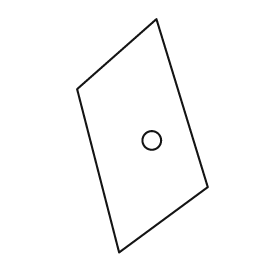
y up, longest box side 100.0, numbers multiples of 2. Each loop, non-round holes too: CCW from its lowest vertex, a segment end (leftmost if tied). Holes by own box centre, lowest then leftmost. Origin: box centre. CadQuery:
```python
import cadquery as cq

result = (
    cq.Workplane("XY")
    .moveTo(-10.0, -50.0)
    .lineTo(28.0, -22.0)
    .lineTo(6.0, 50.0)
    .lineTo(-28.0, 20.0)
    .close()
    .moveTo(4.0, -2.0)
    .circle(4.0)
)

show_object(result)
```